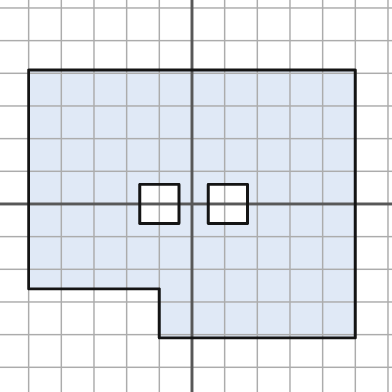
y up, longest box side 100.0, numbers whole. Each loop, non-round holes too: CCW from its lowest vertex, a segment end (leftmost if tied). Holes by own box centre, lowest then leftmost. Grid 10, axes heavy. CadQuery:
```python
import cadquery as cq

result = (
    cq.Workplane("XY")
    .moveTo(-10.0, -41.0)
    .lineTo(50.0, -41.0)
    .lineTo(50.0, 41.0)
    .lineTo(-50.0, 41.0)
    .lineTo(-50.0, -26.0)
    .lineTo(-10.0, -26.0)
    .close()
    .moveTo(-16.0, -6.0)
    .lineTo(-4.0, -6.0)
    .lineTo(-4.0, 6.0)
    .lineTo(-16.0, 6.0)
    .close()
    .moveTo(5.0, -6.0)
    .lineTo(17.0, -6.0)
    .lineTo(17.0, 6.0)
    .lineTo(5.0, 6.0)
    .close()
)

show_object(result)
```